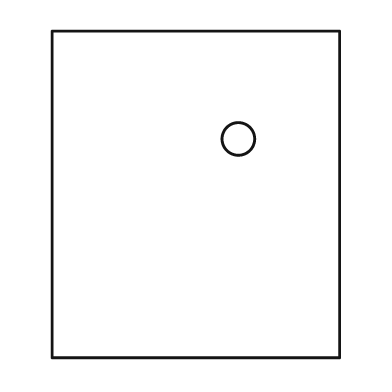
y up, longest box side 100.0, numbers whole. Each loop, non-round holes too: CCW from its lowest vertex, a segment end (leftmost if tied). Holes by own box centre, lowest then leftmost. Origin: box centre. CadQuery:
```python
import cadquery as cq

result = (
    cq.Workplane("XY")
    .moveTo(-44.0, -50.0)
    .lineTo(44.0, -50.0)
    .lineTo(44.0, 50.0)
    .lineTo(-44.0, 50.0)
    .close()
    .moveTo(13.0, 17.0)
    .circle(5.0)
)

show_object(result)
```